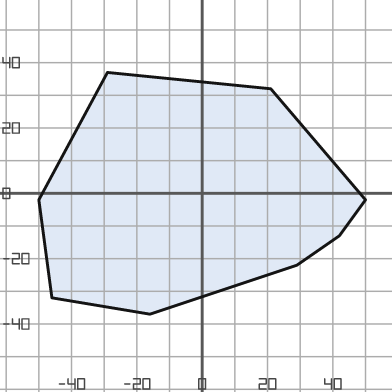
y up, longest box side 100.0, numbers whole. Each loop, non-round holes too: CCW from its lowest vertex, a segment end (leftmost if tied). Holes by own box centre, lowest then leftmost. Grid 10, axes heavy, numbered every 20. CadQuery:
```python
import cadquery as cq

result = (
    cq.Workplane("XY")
    .moveTo(-16.0, -37.0)
    .lineTo(29.0, -22.0)
    .lineTo(42.0, -13.0)
    .lineTo(50.0, -2.0)
    .lineTo(21.0, 32.0)
    .lineTo(-29.0, 37.0)
    .lineTo(-50.0, -2.0)
    .lineTo(-46.0, -32.0)
    .close()
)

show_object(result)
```